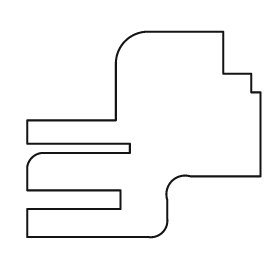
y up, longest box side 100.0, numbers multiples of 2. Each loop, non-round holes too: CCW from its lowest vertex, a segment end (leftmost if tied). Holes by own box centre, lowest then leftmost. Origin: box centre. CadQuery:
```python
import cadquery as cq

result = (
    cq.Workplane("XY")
    .moveTo(-50.0, -44.0)
    .lineTo(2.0, -44.0)
    .threePointArc((8.0, -42.0), (10.0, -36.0))
    .lineTo(10.0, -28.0)
    .threePointArc((12.0, -20.0), (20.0, -18.0))
    .lineTo(50.0, -18.0)
    .lineTo(50.0, 18.0)
    .lineTo(46.0, 18.0)
    .lineTo(46.0, 26.0)
    .lineTo(34.0, 26.0)
    .lineTo(34.0, 44.0)
    .lineTo(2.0, 44.0)
    .threePointArc((-8.0, 40.0), (-12.0, 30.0))
    .lineTo(-12.0, 6.0)
    .lineTo(-50.0, 6.0)
    .lineTo(-50.0, -4.0)
    .lineTo(-6.0, -4.0)
    .lineTo(-6.0, -8.0)
    .lineTo(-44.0, -8.0)
    .threePointArc((-48.0, -10.0), (-50.0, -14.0))
    .lineTo(-50.0, -24.0)
    .lineTo(-10.0, -24.0)
    .lineTo(-10.0, -32.0)
    .lineTo(-50.0, -32.0)
    .close()
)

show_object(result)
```